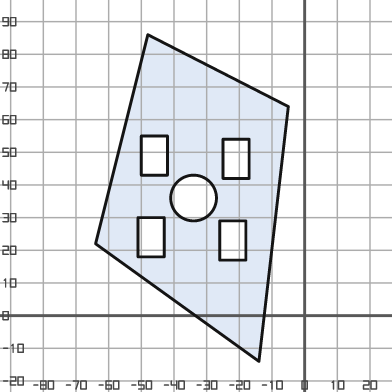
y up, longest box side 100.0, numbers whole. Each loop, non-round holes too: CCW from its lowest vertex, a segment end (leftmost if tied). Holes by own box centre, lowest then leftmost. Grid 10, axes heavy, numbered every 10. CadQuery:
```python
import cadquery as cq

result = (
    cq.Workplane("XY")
    .moveTo(-14.0, -14.0)
    .lineTo(-5.0, 64.0)
    .lineTo(-48.0, 86.0)
    .lineTo(-64.0, 22.0)
    .close()
    .moveTo(-26.0, 17.0)
    .lineTo(-18.0, 17.0)
    .lineTo(-18.0, 29.0)
    .lineTo(-26.0, 29.0)
    .close()
    .moveTo(-51.0, 18.0)
    .lineTo(-43.0, 18.0)
    .lineTo(-43.0, 30.0)
    .lineTo(-51.0, 30.0)
    .close()
    .moveTo(-34.0, 36.0)
    .circle(7.0)
    .moveTo(-25.0, 42.0)
    .lineTo(-17.0, 42.0)
    .lineTo(-17.0, 54.0)
    .lineTo(-25.0, 54.0)
    .close()
    .moveTo(-50.0, 43.0)
    .lineTo(-42.0, 43.0)
    .lineTo(-42.0, 55.0)
    .lineTo(-50.0, 55.0)
    .close()
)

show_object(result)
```